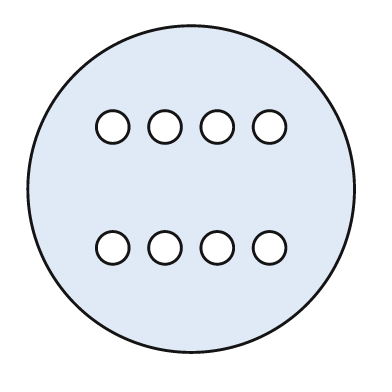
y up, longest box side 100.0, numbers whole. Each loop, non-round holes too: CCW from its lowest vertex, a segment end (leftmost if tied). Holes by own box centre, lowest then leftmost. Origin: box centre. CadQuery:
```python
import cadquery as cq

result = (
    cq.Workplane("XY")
    .moveTo(0.0, 0.0)
    .circle(50.0)
    .moveTo(-24.0, -18.0)
    .circle(5.0)
    .moveTo(-8.0, -18.0)
    .circle(5.0)
    .moveTo(8.0, -18.0)
    .circle(5.0)
    .moveTo(24.0, -18.0)
    .circle(5.0)
    .moveTo(-24.0, 19.0)
    .circle(5.0)
    .moveTo(-8.0, 19.0)
    .circle(5.0)
    .moveTo(8.0, 19.0)
    .circle(5.0)
    .moveTo(24.0, 19.0)
    .circle(5.0)
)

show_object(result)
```